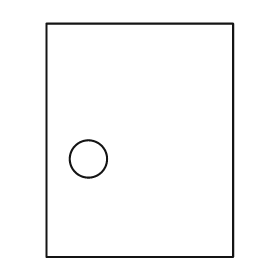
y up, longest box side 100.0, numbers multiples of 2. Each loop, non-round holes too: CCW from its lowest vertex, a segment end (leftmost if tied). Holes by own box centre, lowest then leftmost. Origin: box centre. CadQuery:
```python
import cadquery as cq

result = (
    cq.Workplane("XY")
    .moveTo(-40.0, -50.0)
    .lineTo(40.0, -50.0)
    .lineTo(40.0, 50.0)
    .lineTo(-40.0, 50.0)
    .close()
    .moveTo(-22.0, -8.0)
    .circle(8.0)
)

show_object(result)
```